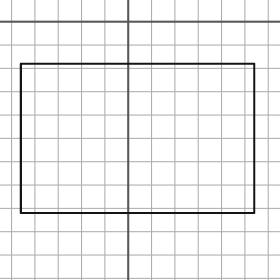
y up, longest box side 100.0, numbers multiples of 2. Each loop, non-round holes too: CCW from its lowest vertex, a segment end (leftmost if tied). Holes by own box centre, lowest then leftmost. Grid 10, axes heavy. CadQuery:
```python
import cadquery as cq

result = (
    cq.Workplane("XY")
    .moveTo(-46.0, -82.0)
    .lineTo(54.0, -82.0)
    .lineTo(54.0, -18.0)
    .lineTo(-46.0, -18.0)
    .close()
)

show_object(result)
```